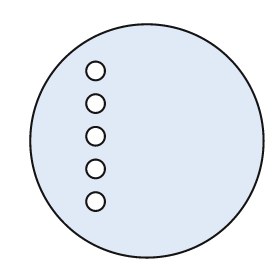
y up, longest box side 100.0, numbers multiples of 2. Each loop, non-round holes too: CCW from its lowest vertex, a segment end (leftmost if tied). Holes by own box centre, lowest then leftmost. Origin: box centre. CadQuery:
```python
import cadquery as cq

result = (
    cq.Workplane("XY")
    .moveTo(0.0, 0.0)
    .circle(50.0)
    .moveTo(-22.0, -26.0)
    .circle(4.0)
    .moveTo(-22.0, -12.0)
    .circle(4.0)
    .moveTo(-22.0, 2.0)
    .circle(4.0)
    .moveTo(-22.0, 16.0)
    .circle(4.0)
    .moveTo(-22.0, 30.0)
    .circle(4.0)
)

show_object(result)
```